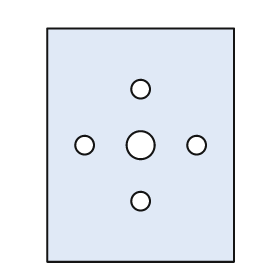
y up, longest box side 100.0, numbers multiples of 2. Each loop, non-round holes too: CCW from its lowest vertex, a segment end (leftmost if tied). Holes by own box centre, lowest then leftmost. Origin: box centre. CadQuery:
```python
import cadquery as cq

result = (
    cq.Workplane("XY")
    .moveTo(-40.0, -50.0)
    .lineTo(40.0, -50.0)
    .lineTo(40.0, 50.0)
    .lineTo(-40.0, 50.0)
    .close()
    .moveTo(0.0, -24.0)
    .circle(4.0)
    .moveTo(-24.0, 0.0)
    .circle(4.0)
    .moveTo(0.0, 0.0)
    .circle(6.0)
    .moveTo(24.0, 0.0)
    .circle(4.0)
    .moveTo(0.0, 24.0)
    .circle(4.0)
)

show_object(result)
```